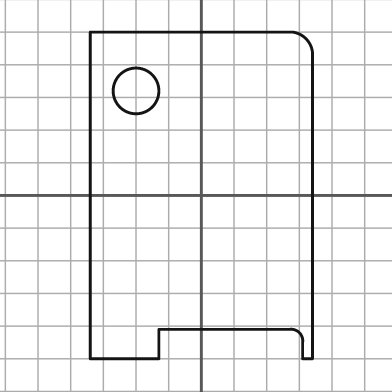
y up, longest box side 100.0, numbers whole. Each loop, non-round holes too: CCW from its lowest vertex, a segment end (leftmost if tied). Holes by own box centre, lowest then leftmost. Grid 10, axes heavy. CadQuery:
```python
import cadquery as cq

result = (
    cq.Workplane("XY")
    .moveTo(-34.0, -50.0)
    .lineTo(-13.0, -50.0)
    .lineTo(-13.0, -41.0)
    .lineTo(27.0, -41.0)
    .threePointArc((30.0, -42.0), (31.0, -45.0))
    .lineTo(31.0, -50.0)
    .lineTo(34.0, -50.0)
    .lineTo(34.0, 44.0)
    .threePointArc((32.0, 48.0), (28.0, 50.0))
    .lineTo(-34.0, 50.0)
    .close()
    .moveTo(-20.0, 32.0)
    .circle(7.0)
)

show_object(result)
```